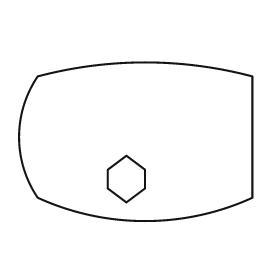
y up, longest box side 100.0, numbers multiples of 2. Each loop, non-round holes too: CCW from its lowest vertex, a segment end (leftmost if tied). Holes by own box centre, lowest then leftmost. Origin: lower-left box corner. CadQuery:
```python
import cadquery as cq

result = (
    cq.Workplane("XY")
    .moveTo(8.0, 10.0)
    .threePointArc((54.0, 0.0), (100.0, 10.0))
    .lineTo(100.0, 62.0)
    .threePointArc((54.0, 68.0), (8.0, 62.0))
    .threePointArc((0.0, 36.0), (8.0, 10.0))
    .close()
    .moveTo(46.0, 8.0)
    .lineTo(54.0, 14.0)
    .lineTo(54.0, 22.0)
    .lineTo(46.0, 28.0)
    .lineTo(38.0, 22.0)
    .lineTo(38.0, 14.0)
    .close()
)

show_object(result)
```